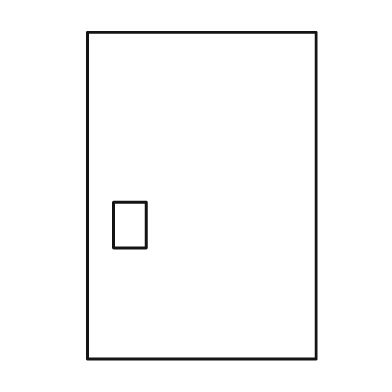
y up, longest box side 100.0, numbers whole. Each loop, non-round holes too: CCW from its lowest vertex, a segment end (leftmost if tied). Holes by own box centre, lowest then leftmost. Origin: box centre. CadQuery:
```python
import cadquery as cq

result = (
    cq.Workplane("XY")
    .moveTo(-35.0, -50.0)
    .lineTo(35.0, -50.0)
    .lineTo(35.0, 50.0)
    .lineTo(-35.0, 50.0)
    .close()
    .moveTo(-27.0, -16.0)
    .lineTo(-17.0, -16.0)
    .lineTo(-17.0, -2.0)
    .lineTo(-27.0, -2.0)
    .close()
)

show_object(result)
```